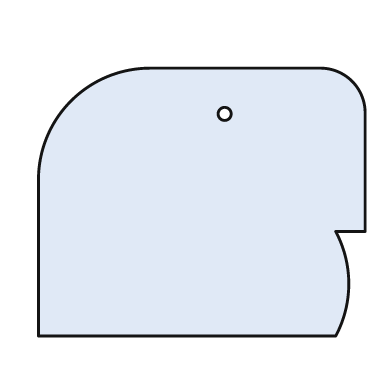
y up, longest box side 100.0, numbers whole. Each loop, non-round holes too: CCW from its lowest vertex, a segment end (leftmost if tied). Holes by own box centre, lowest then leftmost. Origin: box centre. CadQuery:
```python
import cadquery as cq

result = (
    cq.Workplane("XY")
    .moveTo(-50.0, -41.0)
    .lineTo(41.0, -41.0)
    .threePointArc((45.0, -25.0), (41.0, -9.0))
    .lineTo(50.0, -9.0)
    .lineTo(50.0, 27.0)
    .threePointArc((46.0, 37.0), (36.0, 41.0))
    .lineTo(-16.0, 41.0)
    .threePointArc((-40.0, 31.0), (-50.0, 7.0))
    .close()
    .moveTo(7.0, 27.0)
    .circle(2.0)
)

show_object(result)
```